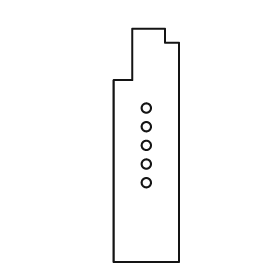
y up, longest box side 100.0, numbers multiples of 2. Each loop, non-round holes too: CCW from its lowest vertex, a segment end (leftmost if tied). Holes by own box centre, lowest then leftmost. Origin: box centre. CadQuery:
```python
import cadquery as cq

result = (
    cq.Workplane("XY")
    .moveTo(-14.0, -50.0)
    .lineTo(14.0, -50.0)
    .lineTo(14.0, 44.0)
    .lineTo(8.0, 44.0)
    .lineTo(8.0, 50.0)
    .lineTo(-6.0, 50.0)
    .lineTo(-6.0, 28.0)
    .lineTo(-14.0, 28.0)
    .close()
    .moveTo(0.0, -16.0)
    .circle(2.0)
    .moveTo(0.0, -8.0)
    .circle(2.0)
    .moveTo(0.0, 0.0)
    .circle(2.0)
    .moveTo(0.0, 8.0)
    .circle(2.0)
    .moveTo(0.0, 16.0)
    .circle(2.0)
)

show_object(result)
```